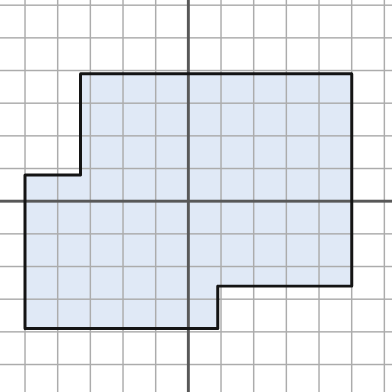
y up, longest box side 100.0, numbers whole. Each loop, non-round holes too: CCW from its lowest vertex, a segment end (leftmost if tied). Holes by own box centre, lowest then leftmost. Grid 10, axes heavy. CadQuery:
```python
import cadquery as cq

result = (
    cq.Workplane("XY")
    .moveTo(-50.0, -39.0)
    .lineTo(9.0, -39.0)
    .lineTo(9.0, -26.0)
    .lineTo(50.0, -26.0)
    .lineTo(50.0, 39.0)
    .lineTo(-33.0, 39.0)
    .lineTo(-33.0, 8.0)
    .lineTo(-50.0, 8.0)
    .close()
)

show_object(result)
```